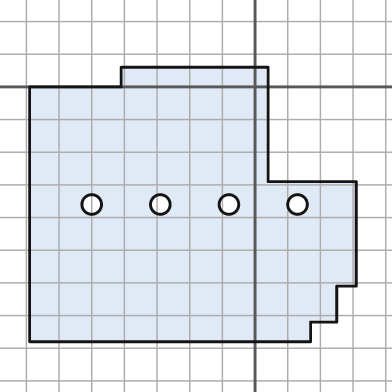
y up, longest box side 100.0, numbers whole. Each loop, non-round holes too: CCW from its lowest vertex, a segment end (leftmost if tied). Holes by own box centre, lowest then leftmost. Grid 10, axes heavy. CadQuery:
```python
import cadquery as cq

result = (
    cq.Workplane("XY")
    .moveTo(-69.0, -78.0)
    .lineTo(17.0, -78.0)
    .lineTo(17.0, -72.0)
    .lineTo(25.0, -72.0)
    .lineTo(25.0, -61.0)
    .lineTo(31.0, -61.0)
    .lineTo(31.0, -29.0)
    .lineTo(4.0, -29.0)
    .lineTo(4.0, 6.0)
    .lineTo(-41.0, 6.0)
    .lineTo(-41.0, 0.0)
    .lineTo(-69.0, 0.0)
    .close()
    .moveTo(-50.0, -36.0)
    .circle(3.0)
    .moveTo(-29.0, -36.0)
    .circle(3.0)
    .moveTo(-8.0, -36.0)
    .circle(3.0)
    .moveTo(13.0, -36.0)
    .circle(3.0)
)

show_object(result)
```